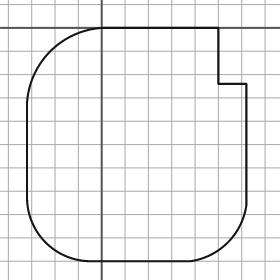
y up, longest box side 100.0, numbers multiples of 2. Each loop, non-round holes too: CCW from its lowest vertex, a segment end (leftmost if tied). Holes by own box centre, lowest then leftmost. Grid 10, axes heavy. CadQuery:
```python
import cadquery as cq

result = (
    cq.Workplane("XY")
    .moveTo(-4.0, -100.0)
    .lineTo(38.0, -100.0)
    .threePointArc((54.0, -92.0), (62.0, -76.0))
    .lineTo(62.0, -24.0)
    .lineTo(50.0, -24.0)
    .lineTo(50.0, 0.0)
    .lineTo(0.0, 0.0)
    .threePointArc((-22.0, -10.0), (-32.0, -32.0))
    .lineTo(-32.0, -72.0)
    .threePointArc((-24.0, -92.0), (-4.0, -100.0))
    .close()
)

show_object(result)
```